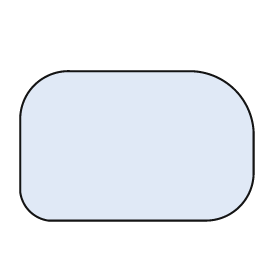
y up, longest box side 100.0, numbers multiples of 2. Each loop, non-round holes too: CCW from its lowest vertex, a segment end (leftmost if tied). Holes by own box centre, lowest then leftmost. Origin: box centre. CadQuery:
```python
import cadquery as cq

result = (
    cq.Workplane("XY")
    .moveTo(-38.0, -32.0)
    .lineTo(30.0, -32.0)
    .threePointArc((44.0, -26.0), (50.0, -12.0))
    .lineTo(50.0, 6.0)
    .threePointArc((42.0, 24.0), (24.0, 32.0))
    .lineTo(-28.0, 32.0)
    .threePointArc((-44.0, 26.0), (-50.0, 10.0))
    .lineTo(-50.0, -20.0)
    .threePointArc((-46.0, -28.0), (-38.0, -32.0))
    .close()
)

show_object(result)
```